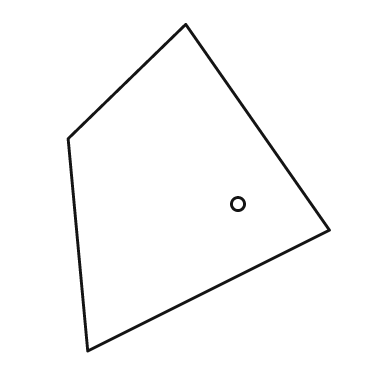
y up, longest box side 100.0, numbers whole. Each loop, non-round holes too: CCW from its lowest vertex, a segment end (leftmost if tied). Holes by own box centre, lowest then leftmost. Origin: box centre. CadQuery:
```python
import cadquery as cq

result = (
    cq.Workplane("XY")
    .moveTo(-34.0, -50.0)
    .lineTo(40.0, -13.0)
    .lineTo(-4.0, 50.0)
    .lineTo(-40.0, 15.0)
    .close()
    .moveTo(12.0, -5.0)
    .circle(2.0)
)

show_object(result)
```